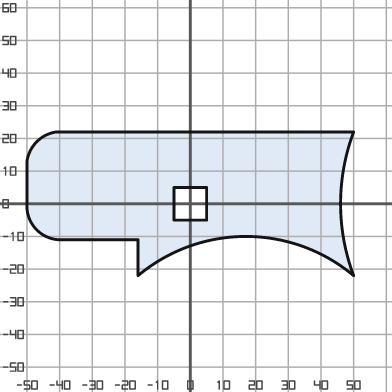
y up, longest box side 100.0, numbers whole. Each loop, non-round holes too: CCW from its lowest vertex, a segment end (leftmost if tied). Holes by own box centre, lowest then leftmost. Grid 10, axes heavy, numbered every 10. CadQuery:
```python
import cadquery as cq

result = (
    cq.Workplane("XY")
    .moveTo(-16.0, -22.0)
    .threePointArc((17.0, -10.0), (50.0, -22.0))
    .threePointArc((46.0, 0.0), (50.0, 22.0))
    .lineTo(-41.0, 22.0)
    .threePointArc((-47.0, 19.0), (-50.0, 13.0))
    .lineTo(-50.0, 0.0)
    .threePointArc((-47.0, -8.0), (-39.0, -11.0))
    .lineTo(-16.0, -11.0)
    .close()
    .moveTo(-5.0, -5.0)
    .lineTo(5.0, -5.0)
    .lineTo(5.0, 5.0)
    .lineTo(-5.0, 5.0)
    .close()
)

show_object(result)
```